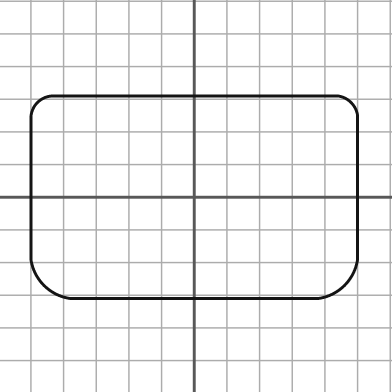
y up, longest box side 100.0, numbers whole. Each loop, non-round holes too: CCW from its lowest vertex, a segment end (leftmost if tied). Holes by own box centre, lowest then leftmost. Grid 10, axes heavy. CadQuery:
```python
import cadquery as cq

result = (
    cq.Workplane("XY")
    .moveTo(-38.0, -31.0)
    .lineTo(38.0, -31.0)
    .threePointArc((46.0, -27.0), (50.0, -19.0))
    .lineTo(50.0, 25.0)
    .threePointArc((48.0, 29.0), (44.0, 31.0))
    .lineTo(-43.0, 31.0)
    .threePointArc((-48.0, 29.0), (-50.0, 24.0))
    .lineTo(-50.0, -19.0)
    .threePointArc((-46.0, -27.0), (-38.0, -31.0))
    .close()
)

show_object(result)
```